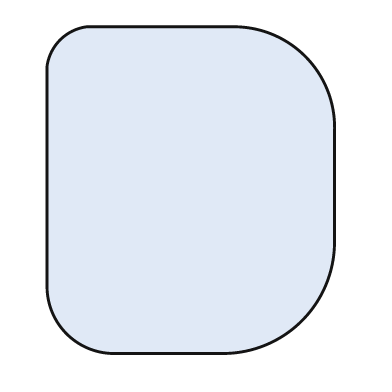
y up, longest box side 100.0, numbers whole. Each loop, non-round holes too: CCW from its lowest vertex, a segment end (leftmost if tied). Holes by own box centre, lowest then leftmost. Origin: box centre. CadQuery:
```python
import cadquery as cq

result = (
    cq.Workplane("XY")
    .moveTo(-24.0, -50.0)
    .lineTo(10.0, -50.0)
    .threePointArc((34.0, -40.0), (44.0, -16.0))
    .lineTo(44.0, 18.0)
    .threePointArc((35.0, 41.0), (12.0, 50.0))
    .lineTo(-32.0, 50.0)
    .threePointArc((-40.0, 46.0), (-44.0, 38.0))
    .lineTo(-44.0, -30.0)
    .threePointArc((-38.0, -44.0), (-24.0, -50.0))
    .close()
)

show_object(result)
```